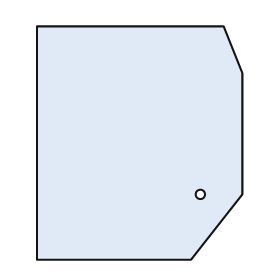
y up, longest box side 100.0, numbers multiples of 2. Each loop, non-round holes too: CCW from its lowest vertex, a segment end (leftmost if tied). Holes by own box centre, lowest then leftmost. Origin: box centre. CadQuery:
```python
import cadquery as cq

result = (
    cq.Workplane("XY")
    .moveTo(-44.0, -50.0)
    .lineTo(22.0, -50.0)
    .lineTo(44.0, -22.0)
    .lineTo(44.0, 30.0)
    .lineTo(36.0, 50.0)
    .lineTo(-44.0, 50.0)
    .close()
    .moveTo(26.0, -22.0)
    .circle(2.0)
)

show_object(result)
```